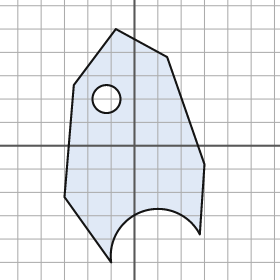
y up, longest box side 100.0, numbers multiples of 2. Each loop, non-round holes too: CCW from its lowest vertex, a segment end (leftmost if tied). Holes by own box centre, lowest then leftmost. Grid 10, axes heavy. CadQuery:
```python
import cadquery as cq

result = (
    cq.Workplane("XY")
    .moveTo(-10.0, -50.0)
    .threePointArc((4.0, -28.0), (28.0, -38.0))
    .lineTo(30.0, -8.0)
    .lineTo(14.0, 38.0)
    .lineTo(-8.0, 50.0)
    .lineTo(-26.0, 26.0)
    .lineTo(-30.0, -22.0)
    .close()
    .moveTo(-12.0, 20.0)
    .circle(6.0)
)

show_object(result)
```